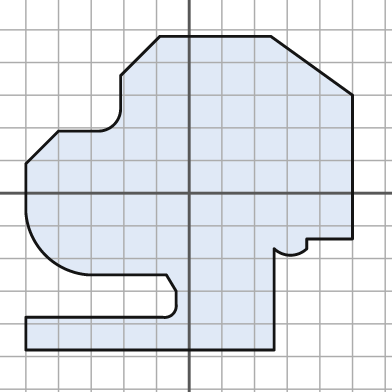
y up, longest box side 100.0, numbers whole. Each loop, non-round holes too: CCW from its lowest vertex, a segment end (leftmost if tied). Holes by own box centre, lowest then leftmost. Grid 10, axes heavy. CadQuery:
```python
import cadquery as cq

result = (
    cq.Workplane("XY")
    .moveTo(-50.0, -48.0)
    .lineTo(26.0, -48.0)
    .lineTo(26.0, -17.0)
    .threePointArc((31.0, -19.0), (36.0, -17.0))
    .lineTo(36.0, -14.0)
    .lineTo(50.0, -14.0)
    .lineTo(50.0, 30.0)
    .lineTo(25.0, 48.0)
    .lineTo(-9.0, 48.0)
    .lineTo(-21.0, 36.0)
    .lineTo(-21.0, 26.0)
    .threePointArc((-23.0, 21.0), (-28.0, 19.0))
    .lineTo(-40.0, 19.0)
    .lineTo(-50.0, 9.0)
    .lineTo(-50.0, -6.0)
    .threePointArc((-44.0, -19.0), (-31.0, -25.0))
    .lineTo(-7.0, -25.0)
    .lineTo(-4.0, -30.0)
    .lineTo(-4.0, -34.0)
    .threePointArc((-5.0, -37.0), (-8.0, -38.0))
    .lineTo(-50.0, -38.0)
    .close()
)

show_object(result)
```